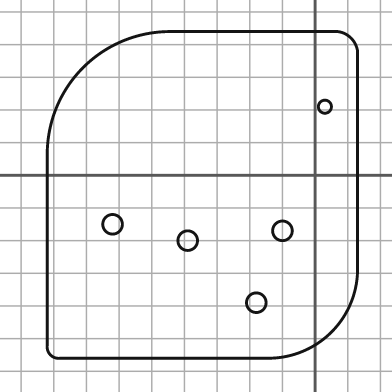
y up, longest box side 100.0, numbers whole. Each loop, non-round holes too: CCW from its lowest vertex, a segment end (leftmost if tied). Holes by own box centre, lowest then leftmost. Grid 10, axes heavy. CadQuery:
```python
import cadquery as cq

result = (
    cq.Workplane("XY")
    .moveTo(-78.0, -56.0)
    .lineTo(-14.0, -56.0)
    .threePointArc((5.0, -48.0), (13.0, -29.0))
    .lineTo(13.0, 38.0)
    .threePointArc((11.0, 42.0), (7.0, 44.0))
    .lineTo(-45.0, 44.0)
    .threePointArc((-71.0, 33.0), (-82.0, 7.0))
    .lineTo(-82.0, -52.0)
    .threePointArc((-81.0, -55.0), (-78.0, -56.0))
    .close()
    .moveTo(-18.0, -39.0)
    .circle(3.0)
    .moveTo(-39.0, -20.0)
    .circle(3.0)
    .moveTo(-10.0, -17.0)
    .circle(3.0)
    .moveTo(-62.0, -15.0)
    .circle(3.0)
    .moveTo(3.0, 21.0)
    .circle(2.0)
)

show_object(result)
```